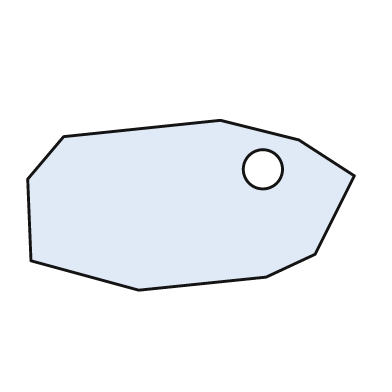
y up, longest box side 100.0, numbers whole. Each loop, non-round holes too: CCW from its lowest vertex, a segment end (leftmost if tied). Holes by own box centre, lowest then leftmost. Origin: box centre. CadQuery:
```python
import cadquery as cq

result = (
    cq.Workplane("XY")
    .moveTo(-16.0, -26.0)
    .lineTo(23.0, -22.0)
    .lineTo(38.0, -15.0)
    .lineTo(50.0, 9.0)
    .lineTo(33.0, 20.0)
    .lineTo(9.0, 26.0)
    .lineTo(-39.0, 21.0)
    .lineTo(-50.0, 8.0)
    .lineTo(-49.0, -17.0)
    .close()
    .moveTo(22.0, 11.0)
    .circle(6.0)
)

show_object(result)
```